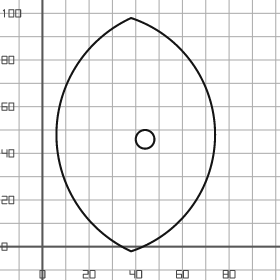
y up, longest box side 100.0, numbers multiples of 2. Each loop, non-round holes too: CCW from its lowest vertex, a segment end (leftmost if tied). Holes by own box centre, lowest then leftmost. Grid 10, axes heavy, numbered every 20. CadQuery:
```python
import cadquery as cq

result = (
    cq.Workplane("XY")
    .moveTo(38.0, -2.0)
    .threePointArc((74.0, 48.0), (38.0, 98.0))
    .threePointArc((6.0, 48.0), (38.0, -2.0))
    .close()
    .moveTo(44.0, 46.0)
    .circle(4.0)
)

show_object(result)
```